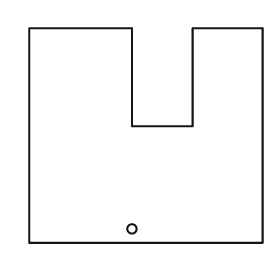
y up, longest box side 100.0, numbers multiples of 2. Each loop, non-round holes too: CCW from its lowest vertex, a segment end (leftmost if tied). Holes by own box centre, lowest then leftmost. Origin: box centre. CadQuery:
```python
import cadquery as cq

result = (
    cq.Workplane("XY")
    .moveTo(-50.0, -46.0)
    .lineTo(50.0, -46.0)
    .lineTo(50.0, 46.0)
    .lineTo(20.0, 46.0)
    .lineTo(20.0, 4.0)
    .lineTo(-6.0, 4.0)
    .lineTo(-6.0, 46.0)
    .lineTo(-50.0, 46.0)
    .close()
    .moveTo(-6.0, -40.0)
    .circle(2.0)
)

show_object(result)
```